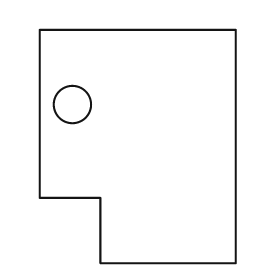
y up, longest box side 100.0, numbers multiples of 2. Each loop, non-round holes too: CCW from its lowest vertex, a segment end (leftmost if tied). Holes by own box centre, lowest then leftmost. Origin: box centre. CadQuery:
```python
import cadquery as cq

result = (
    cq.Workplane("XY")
    .moveTo(-16.0, -50.0)
    .lineTo(42.0, -50.0)
    .lineTo(42.0, 50.0)
    .lineTo(-42.0, 50.0)
    .lineTo(-42.0, -22.0)
    .lineTo(-16.0, -22.0)
    .close()
    .moveTo(-28.0, 18.0)
    .circle(8.0)
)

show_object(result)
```